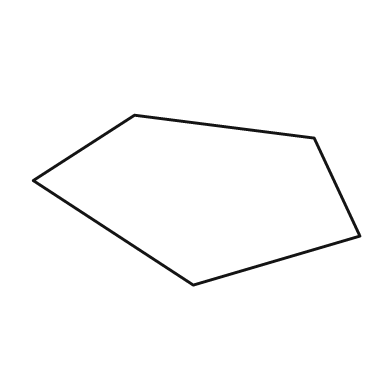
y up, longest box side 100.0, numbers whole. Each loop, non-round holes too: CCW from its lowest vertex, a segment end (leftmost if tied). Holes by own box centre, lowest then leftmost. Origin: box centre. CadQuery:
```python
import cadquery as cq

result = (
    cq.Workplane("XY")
    .moveTo(-1.0, -26.0)
    .lineTo(50.0, -11.0)
    .lineTo(36.0, 19.0)
    .lineTo(-19.0, 26.0)
    .lineTo(-50.0, 6.0)
    .close()
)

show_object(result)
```